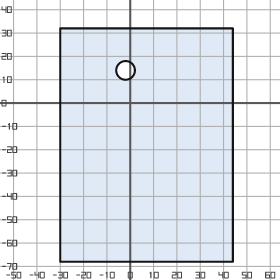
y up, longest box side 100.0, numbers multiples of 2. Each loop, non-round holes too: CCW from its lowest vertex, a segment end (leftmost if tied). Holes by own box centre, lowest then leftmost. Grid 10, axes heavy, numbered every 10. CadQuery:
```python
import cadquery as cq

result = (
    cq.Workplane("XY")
    .moveTo(-30.0, -68.0)
    .lineTo(44.0, -68.0)
    .lineTo(44.0, 32.0)
    .lineTo(-30.0, 32.0)
    .close()
    .moveTo(-2.0, 14.0)
    .circle(4.0)
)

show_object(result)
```